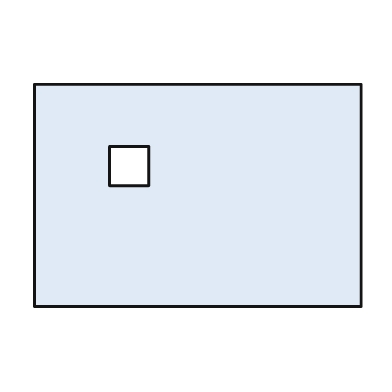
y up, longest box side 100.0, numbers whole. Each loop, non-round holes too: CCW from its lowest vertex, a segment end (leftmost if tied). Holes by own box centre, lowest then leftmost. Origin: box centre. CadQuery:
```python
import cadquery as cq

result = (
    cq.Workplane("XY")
    .moveTo(-50.0, -34.0)
    .lineTo(50.0, -34.0)
    .lineTo(50.0, 34.0)
    .lineTo(-50.0, 34.0)
    .close()
    .moveTo(-27.0, 3.0)
    .lineTo(-15.0, 3.0)
    .lineTo(-15.0, 15.0)
    .lineTo(-27.0, 15.0)
    .close()
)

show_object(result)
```